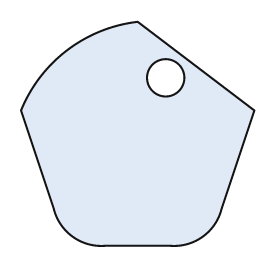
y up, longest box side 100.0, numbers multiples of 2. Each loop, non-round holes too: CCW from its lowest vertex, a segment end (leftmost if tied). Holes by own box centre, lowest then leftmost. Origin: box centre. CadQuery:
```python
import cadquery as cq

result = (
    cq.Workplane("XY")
    .moveTo(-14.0, -48.0)
    .lineTo(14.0, -48.0)
    .threePointArc((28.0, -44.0), (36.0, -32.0))
    .lineTo(50.0, 10.0)
    .lineTo(0.0, 48.0)
    .threePointArc((-30.0, 36.0), (-50.0, 10.0))
    .lineTo(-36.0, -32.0)
    .threePointArc((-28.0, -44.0), (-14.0, -48.0))
    .close()
    .moveTo(12.0, 24.0)
    .circle(8.0)
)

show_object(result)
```